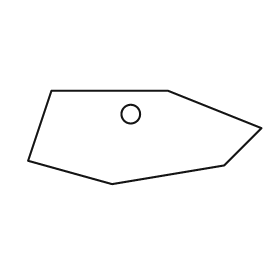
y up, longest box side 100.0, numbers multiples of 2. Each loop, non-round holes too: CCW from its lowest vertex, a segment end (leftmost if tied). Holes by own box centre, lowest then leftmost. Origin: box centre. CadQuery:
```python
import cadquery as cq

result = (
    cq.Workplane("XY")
    .moveTo(-14.0, -20.0)
    .lineTo(34.0, -12.0)
    .lineTo(50.0, 4.0)
    .lineTo(10.0, 20.0)
    .lineTo(-40.0, 20.0)
    .lineTo(-50.0, -10.0)
    .close()
    .moveTo(-6.0, 10.0)
    .circle(4.0)
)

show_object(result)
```